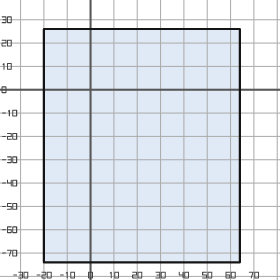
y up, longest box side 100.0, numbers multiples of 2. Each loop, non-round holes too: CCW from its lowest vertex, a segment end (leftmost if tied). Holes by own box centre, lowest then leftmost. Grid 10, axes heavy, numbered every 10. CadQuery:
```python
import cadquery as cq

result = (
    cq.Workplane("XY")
    .moveTo(-20.0, -74.0)
    .lineTo(64.0, -74.0)
    .lineTo(64.0, 26.0)
    .lineTo(-20.0, 26.0)
    .close()
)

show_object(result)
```